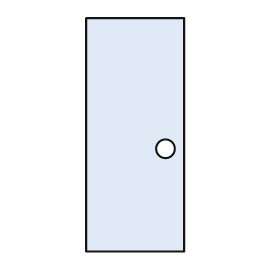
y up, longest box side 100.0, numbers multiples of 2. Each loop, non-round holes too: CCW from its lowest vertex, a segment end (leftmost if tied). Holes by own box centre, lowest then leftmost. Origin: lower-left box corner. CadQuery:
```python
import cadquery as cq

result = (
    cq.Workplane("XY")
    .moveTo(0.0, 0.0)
    .lineTo(42.0, 0.0)
    .lineTo(42.0, 100.0)
    .lineTo(0.0, 100.0)
    .close()
    .moveTo(34.0, 44.0)
    .circle(4.0)
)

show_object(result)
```